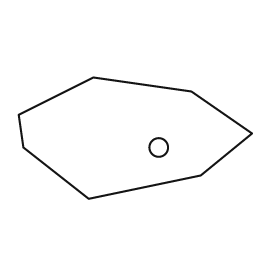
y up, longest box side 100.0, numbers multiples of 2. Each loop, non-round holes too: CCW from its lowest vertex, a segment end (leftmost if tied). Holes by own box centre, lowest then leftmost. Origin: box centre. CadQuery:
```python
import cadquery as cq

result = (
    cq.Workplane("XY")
    .moveTo(-20.0, -26.0)
    .lineTo(28.0, -16.0)
    .lineTo(50.0, 2.0)
    .lineTo(24.0, 20.0)
    .lineTo(-18.0, 26.0)
    .lineTo(-50.0, 10.0)
    .lineTo(-48.0, -4.0)
    .close()
    .moveTo(10.0, -4.0)
    .circle(4.0)
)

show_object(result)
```